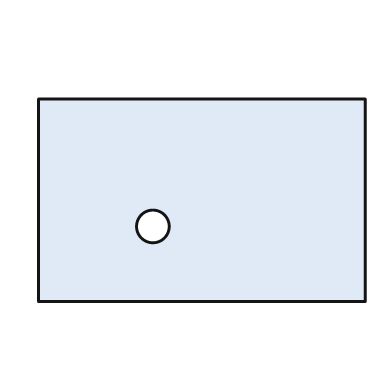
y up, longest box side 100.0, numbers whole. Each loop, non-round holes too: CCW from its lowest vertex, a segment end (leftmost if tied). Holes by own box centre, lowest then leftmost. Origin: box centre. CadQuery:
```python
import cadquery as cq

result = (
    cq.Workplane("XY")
    .moveTo(-50.0, -31.0)
    .lineTo(50.0, -31.0)
    .lineTo(50.0, 31.0)
    .lineTo(-50.0, 31.0)
    .close()
    .moveTo(-15.0, -8.0)
    .circle(5.0)
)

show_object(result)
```